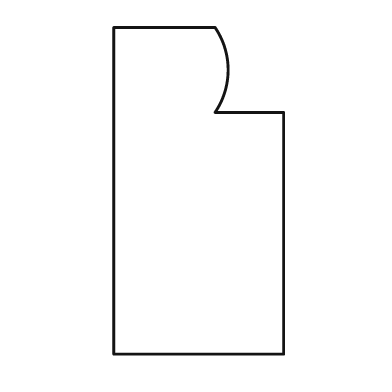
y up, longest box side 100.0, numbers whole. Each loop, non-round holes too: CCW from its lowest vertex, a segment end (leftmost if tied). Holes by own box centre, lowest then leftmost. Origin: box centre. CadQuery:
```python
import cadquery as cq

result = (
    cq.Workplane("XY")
    .moveTo(-26.0, -50.0)
    .lineTo(26.0, -50.0)
    .lineTo(26.0, 24.0)
    .lineTo(5.0, 24.0)
    .threePointArc((9.0, 37.0), (5.0, 50.0))
    .lineTo(-26.0, 50.0)
    .close()
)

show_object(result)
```